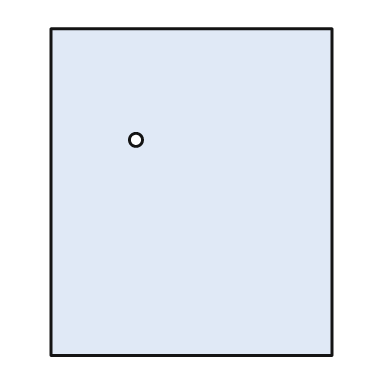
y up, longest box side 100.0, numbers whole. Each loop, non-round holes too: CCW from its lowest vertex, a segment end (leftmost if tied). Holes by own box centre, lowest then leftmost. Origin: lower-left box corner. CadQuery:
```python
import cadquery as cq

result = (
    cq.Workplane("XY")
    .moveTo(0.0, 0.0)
    .lineTo(86.0, 0.0)
    .lineTo(86.0, 100.0)
    .lineTo(0.0, 100.0)
    .close()
    .moveTo(26.0, 66.0)
    .circle(2.0)
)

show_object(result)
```